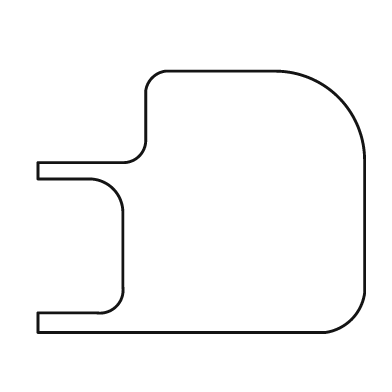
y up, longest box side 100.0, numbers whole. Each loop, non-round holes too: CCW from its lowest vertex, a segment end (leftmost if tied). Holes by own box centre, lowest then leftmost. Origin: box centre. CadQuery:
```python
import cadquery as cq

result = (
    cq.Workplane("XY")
    .moveTo(-50.0, -40.0)
    .lineTo(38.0, -40.0)
    .threePointArc((46.0, -36.0), (50.0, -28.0))
    .lineTo(50.0, 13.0)
    .threePointArc((42.0, 32.0), (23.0, 40.0))
    .lineTo(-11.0, 40.0)
    .threePointArc((-15.0, 38.0), (-17.0, 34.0))
    .lineTo(-17.0, 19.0)
    .threePointArc((-19.0, 14.0), (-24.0, 12.0))
    .lineTo(-50.0, 12.0)
    .lineTo(-50.0, 7.0)
    .lineTo(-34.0, 7.0)
    .threePointArc((-27.0, 4.0), (-24.0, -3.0))
    .lineTo(-24.0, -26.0)
    .threePointArc((-26.0, -32.0), (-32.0, -34.0))
    .lineTo(-50.0, -34.0)
    .close()
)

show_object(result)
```